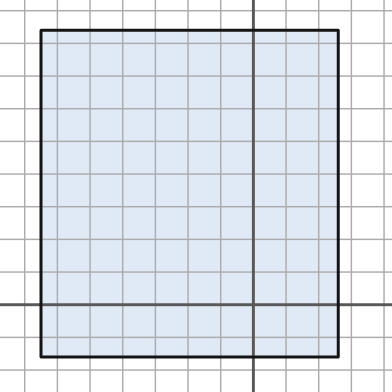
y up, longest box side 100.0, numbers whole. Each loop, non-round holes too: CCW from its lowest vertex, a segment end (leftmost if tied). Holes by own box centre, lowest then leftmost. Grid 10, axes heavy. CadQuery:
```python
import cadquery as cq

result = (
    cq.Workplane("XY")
    .moveTo(-65.0, -16.0)
    .lineTo(26.0, -16.0)
    .lineTo(26.0, 84.0)
    .lineTo(-65.0, 84.0)
    .close()
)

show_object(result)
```